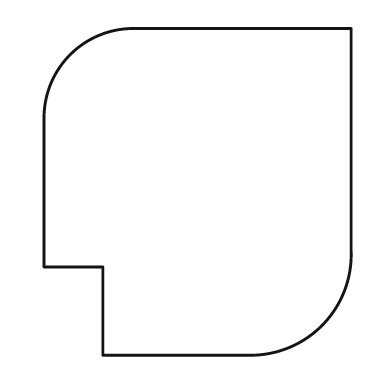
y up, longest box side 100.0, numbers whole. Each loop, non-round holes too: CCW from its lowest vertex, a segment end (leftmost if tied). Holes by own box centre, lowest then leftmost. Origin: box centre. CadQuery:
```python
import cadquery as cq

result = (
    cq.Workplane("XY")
    .moveTo(-29.0, -50.0)
    .lineTo(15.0, -50.0)
    .threePointArc((38.0, -41.0), (47.0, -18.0))
    .lineTo(47.0, 50.0)
    .lineTo(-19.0, 50.0)
    .threePointArc((-39.0, 42.0), (-47.0, 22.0))
    .lineTo(-47.0, -23.0)
    .lineTo(-29.0, -23.0)
    .close()
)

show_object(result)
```